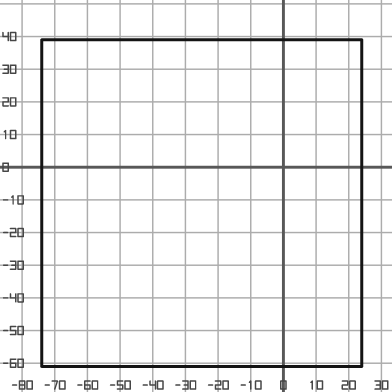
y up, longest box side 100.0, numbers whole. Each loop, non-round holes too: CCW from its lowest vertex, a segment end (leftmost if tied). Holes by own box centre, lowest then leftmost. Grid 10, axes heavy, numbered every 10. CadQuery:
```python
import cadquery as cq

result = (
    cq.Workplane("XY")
    .moveTo(-74.0, -61.0)
    .lineTo(24.0, -61.0)
    .lineTo(24.0, 39.0)
    .lineTo(-74.0, 39.0)
    .close()
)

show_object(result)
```